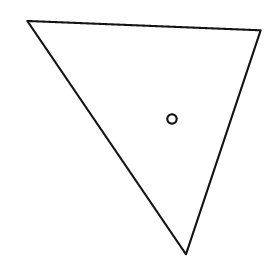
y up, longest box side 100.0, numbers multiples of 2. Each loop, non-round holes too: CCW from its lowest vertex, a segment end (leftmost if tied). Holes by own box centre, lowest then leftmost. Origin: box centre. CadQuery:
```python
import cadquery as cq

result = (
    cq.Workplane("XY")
    .moveTo(18.0, -50.0)
    .lineTo(50.0, 46.0)
    .lineTo(-50.0, 50.0)
    .close()
    .moveTo(12.0, 8.0)
    .circle(2.0)
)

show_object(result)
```